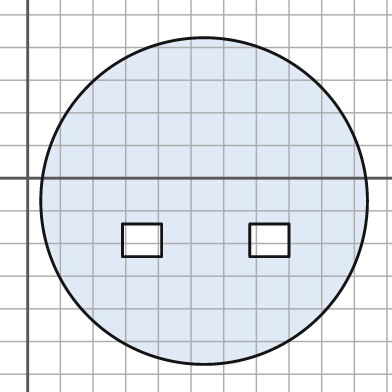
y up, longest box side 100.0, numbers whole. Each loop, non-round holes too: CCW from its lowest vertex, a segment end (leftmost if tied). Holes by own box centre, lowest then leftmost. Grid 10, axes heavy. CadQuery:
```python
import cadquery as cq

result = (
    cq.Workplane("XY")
    .moveTo(54.0, -7.0)
    .circle(50.0)
    .moveTo(29.0, -24.0)
    .lineTo(41.0, -24.0)
    .lineTo(41.0, -14.0)
    .lineTo(29.0, -14.0)
    .close()
    .moveTo(68.0, -24.0)
    .lineTo(80.0, -24.0)
    .lineTo(80.0, -14.0)
    .lineTo(68.0, -14.0)
    .close()
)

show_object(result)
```